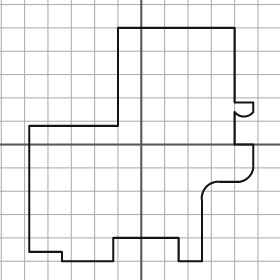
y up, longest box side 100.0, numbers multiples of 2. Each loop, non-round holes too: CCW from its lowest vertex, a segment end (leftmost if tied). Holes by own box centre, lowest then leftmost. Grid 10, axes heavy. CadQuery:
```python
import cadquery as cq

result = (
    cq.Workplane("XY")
    .moveTo(-34.0, -50.0)
    .lineTo(-12.0, -50.0)
    .lineTo(-12.0, -40.0)
    .lineTo(16.0, -40.0)
    .lineTo(16.0, -50.0)
    .lineTo(26.0, -50.0)
    .lineTo(26.0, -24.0)
    .threePointArc((28.0, -18.0), (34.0, -16.0))
    .lineTo(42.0, -16.0)
    .threePointArc((46.0, -14.0), (48.0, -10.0))
    .lineTo(48.0, 0.0)
    .lineTo(40.0, 0.0)
    .lineTo(40.0, 14.0)
    .threePointArc((44.0, 12.0), (48.0, 14.0))
    .lineTo(48.0, 18.0)
    .lineTo(40.0, 18.0)
    .lineTo(40.0, 50.0)
    .lineTo(-10.0, 50.0)
    .lineTo(-10.0, 8.0)
    .lineTo(-48.0, 8.0)
    .lineTo(-48.0, -46.0)
    .lineTo(-34.0, -46.0)
    .close()
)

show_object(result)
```